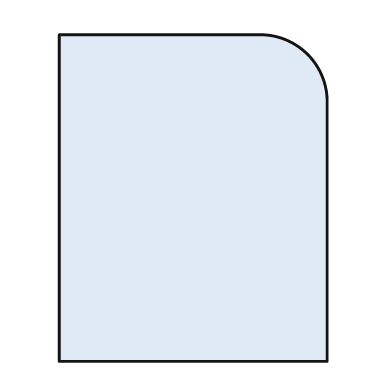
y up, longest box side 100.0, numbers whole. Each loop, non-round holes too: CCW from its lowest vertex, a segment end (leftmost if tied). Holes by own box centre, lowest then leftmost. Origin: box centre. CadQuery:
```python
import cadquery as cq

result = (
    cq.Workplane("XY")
    .moveTo(-41.0, -50.0)
    .lineTo(41.0, -50.0)
    .lineTo(41.0, 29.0)
    .threePointArc((35.0, 44.0), (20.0, 50.0))
    .lineTo(-41.0, 50.0)
    .close()
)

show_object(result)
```